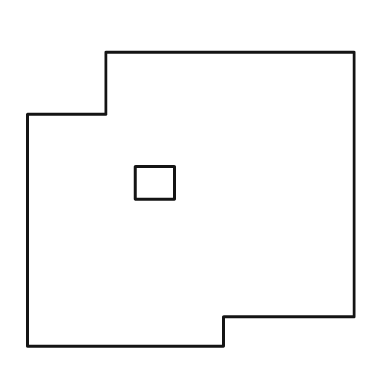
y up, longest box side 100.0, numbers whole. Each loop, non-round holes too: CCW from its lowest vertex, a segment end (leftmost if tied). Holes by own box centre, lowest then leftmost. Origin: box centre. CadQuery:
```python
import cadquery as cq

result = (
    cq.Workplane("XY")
    .moveTo(-50.0, -45.0)
    .lineTo(10.0, -45.0)
    .lineTo(10.0, -36.0)
    .lineTo(50.0, -36.0)
    .lineTo(50.0, 45.0)
    .lineTo(-26.0, 45.0)
    .lineTo(-26.0, 26.0)
    .lineTo(-50.0, 26.0)
    .close()
    .moveTo(-17.0, 0.0)
    .lineTo(-5.0, 0.0)
    .lineTo(-5.0, 10.0)
    .lineTo(-17.0, 10.0)
    .close()
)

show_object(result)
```